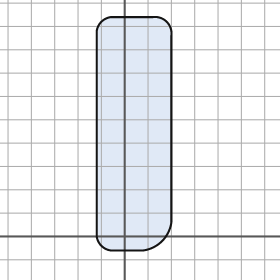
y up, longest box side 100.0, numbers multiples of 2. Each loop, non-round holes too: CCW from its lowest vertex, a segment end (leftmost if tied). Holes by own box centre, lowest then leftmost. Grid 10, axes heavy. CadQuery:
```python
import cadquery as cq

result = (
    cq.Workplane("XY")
    .moveTo(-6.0, -6.0)
    .lineTo(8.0, -6.0)
    .threePointArc((16.0, -2.0), (20.0, 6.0))
    .lineTo(20.0, 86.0)
    .threePointArc((18.0, 92.0), (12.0, 94.0))
    .lineTo(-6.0, 94.0)
    .threePointArc((-10.0, 92.0), (-12.0, 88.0))
    .lineTo(-12.0, 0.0)
    .threePointArc((-10.0, -4.0), (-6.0, -6.0))
    .close()
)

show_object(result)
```